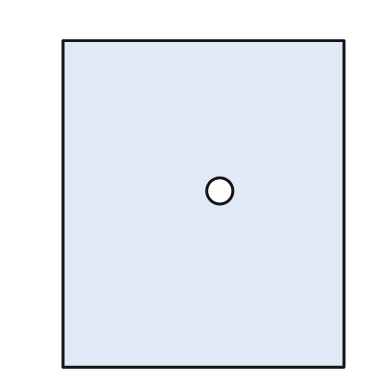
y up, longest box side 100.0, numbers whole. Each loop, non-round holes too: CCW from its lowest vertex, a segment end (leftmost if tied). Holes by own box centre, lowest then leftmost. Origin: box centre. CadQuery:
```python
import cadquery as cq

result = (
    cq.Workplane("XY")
    .moveTo(-43.0, -50.0)
    .lineTo(43.0, -50.0)
    .lineTo(43.0, 50.0)
    .lineTo(-43.0, 50.0)
    .close()
    .moveTo(5.0, 4.0)
    .circle(4.0)
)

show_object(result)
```